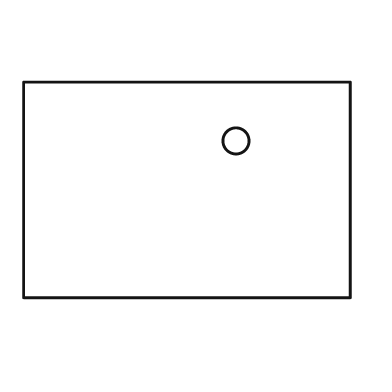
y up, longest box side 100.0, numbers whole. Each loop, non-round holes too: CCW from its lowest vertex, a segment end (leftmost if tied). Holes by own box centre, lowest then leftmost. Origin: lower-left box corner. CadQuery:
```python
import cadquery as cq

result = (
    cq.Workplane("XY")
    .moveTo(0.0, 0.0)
    .lineTo(100.0, 0.0)
    .lineTo(100.0, 66.0)
    .lineTo(0.0, 66.0)
    .close()
    .moveTo(65.0, 48.0)
    .circle(4.0)
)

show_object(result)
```